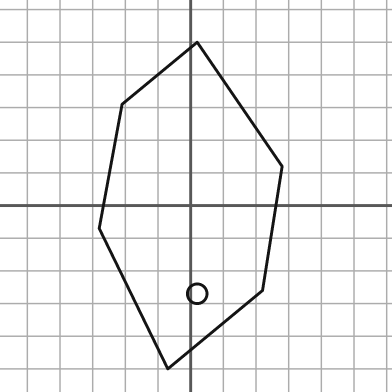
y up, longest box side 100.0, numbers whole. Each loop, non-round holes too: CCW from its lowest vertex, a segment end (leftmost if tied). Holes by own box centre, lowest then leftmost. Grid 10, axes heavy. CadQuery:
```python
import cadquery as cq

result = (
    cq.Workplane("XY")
    .moveTo(-7.0, -50.0)
    .lineTo(22.0, -26.0)
    .lineTo(28.0, 12.0)
    .lineTo(2.0, 50.0)
    .lineTo(-21.0, 31.0)
    .lineTo(-28.0, -7.0)
    .close()
    .moveTo(2.0, -27.0)
    .circle(3.0)
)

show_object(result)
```